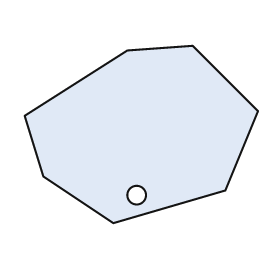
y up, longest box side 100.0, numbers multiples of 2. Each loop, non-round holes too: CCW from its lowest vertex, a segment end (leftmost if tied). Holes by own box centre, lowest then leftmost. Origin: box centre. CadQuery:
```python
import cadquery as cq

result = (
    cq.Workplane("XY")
    .moveTo(-12.0, -38.0)
    .lineTo(36.0, -24.0)
    .lineTo(50.0, 10.0)
    .lineTo(22.0, 38.0)
    .lineTo(-6.0, 36.0)
    .lineTo(-50.0, 8.0)
    .lineTo(-42.0, -18.0)
    .close()
    .moveTo(-2.0, -26.0)
    .circle(4.0)
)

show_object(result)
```